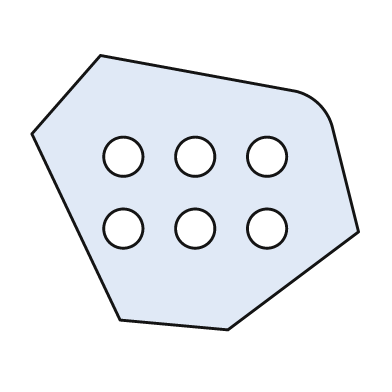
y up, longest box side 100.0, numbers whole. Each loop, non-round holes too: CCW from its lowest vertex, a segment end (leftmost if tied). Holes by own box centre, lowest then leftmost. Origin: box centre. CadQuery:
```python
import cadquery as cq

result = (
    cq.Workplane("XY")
    .moveTo(10.0, -42.0)
    .lineTo(50.0, -12.0)
    .lineTo(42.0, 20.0)
    .threePointArc((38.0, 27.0), (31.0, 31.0))
    .lineTo(-29.0, 42.0)
    .lineTo(-50.0, 18.0)
    .lineTo(-23.0, -39.0)
    .close()
    .moveTo(-22.0, -11.0)
    .circle(6.0)
    .moveTo(0.0, -11.0)
    .circle(6.0)
    .moveTo(22.0, -11.0)
    .circle(6.0)
    .moveTo(-22.0, 11.0)
    .circle(6.0)
    .moveTo(0.0, 11.0)
    .circle(6.0)
    .moveTo(22.0, 11.0)
    .circle(6.0)
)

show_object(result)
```